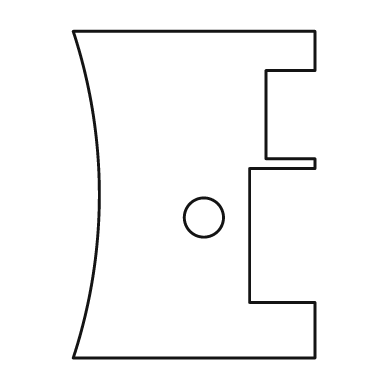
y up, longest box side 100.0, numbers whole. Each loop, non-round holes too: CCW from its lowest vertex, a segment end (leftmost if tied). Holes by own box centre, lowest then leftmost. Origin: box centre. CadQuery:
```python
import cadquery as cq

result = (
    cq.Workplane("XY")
    .moveTo(-37.0, -50.0)
    .lineTo(37.0, -50.0)
    .lineTo(37.0, -33.0)
    .lineTo(17.0, -33.0)
    .lineTo(17.0, 8.0)
    .lineTo(37.0, 8.0)
    .lineTo(37.0, 11.0)
    .lineTo(22.0, 11.0)
    .lineTo(22.0, 38.0)
    .lineTo(37.0, 38.0)
    .lineTo(37.0, 50.0)
    .lineTo(-37.0, 50.0)
    .threePointArc((-29.0, 0.0), (-37.0, -50.0))
    .close()
    .moveTo(3.0, -7.0)
    .circle(6.0)
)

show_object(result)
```